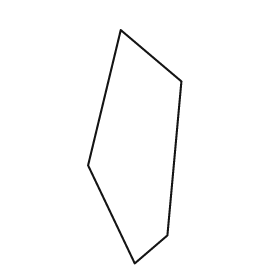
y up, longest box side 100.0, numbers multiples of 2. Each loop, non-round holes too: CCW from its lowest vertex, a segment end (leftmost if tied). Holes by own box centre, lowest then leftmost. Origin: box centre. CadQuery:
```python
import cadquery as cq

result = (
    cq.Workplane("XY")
    .moveTo(0.0, -50.0)
    .lineTo(14.0, -38.0)
    .lineTo(20.0, 28.0)
    .lineTo(-6.0, 50.0)
    .lineTo(-20.0, -8.0)
    .close()
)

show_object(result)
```